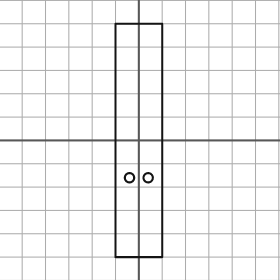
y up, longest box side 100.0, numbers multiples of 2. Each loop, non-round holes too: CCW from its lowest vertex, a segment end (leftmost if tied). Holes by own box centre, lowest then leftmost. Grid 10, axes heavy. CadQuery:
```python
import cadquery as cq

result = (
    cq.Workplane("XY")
    .moveTo(-10.0, -50.0)
    .lineTo(10.0, -50.0)
    .lineTo(10.0, 50.0)
    .lineTo(-10.0, 50.0)
    .close()
    .moveTo(-4.0, -16.0)
    .circle(2.0)
    .moveTo(4.0, -16.0)
    .circle(2.0)
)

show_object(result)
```